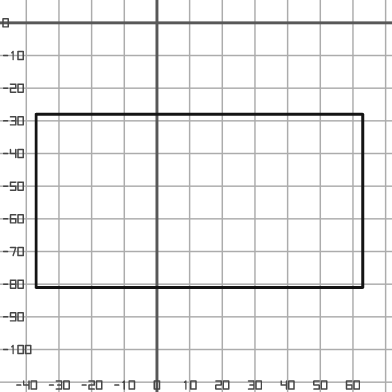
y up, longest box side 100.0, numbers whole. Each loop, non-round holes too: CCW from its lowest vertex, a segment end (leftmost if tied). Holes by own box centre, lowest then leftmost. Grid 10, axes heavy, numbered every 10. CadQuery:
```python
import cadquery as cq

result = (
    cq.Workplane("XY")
    .moveTo(-37.0, -81.0)
    .lineTo(63.0, -81.0)
    .lineTo(63.0, -28.0)
    .lineTo(-37.0, -28.0)
    .close()
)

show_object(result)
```